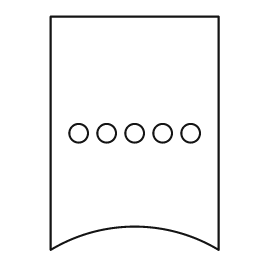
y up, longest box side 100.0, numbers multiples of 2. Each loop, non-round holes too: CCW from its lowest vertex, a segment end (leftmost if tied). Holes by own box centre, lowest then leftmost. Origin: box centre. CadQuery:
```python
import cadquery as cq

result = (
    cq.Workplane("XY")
    .moveTo(-36.0, -50.0)
    .threePointArc((0.0, -40.0), (36.0, -50.0))
    .lineTo(36.0, 50.0)
    .lineTo(-36.0, 50.0)
    .close()
    .moveTo(-24.0, 0.0)
    .circle(4.0)
    .moveTo(-12.0, 0.0)
    .circle(4.0)
    .moveTo(0.0, 0.0)
    .circle(4.0)
    .moveTo(12.0, 0.0)
    .circle(4.0)
    .moveTo(24.0, 0.0)
    .circle(4.0)
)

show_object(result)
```